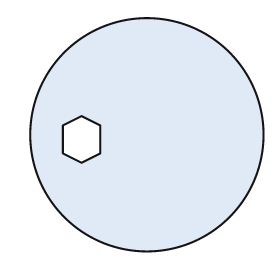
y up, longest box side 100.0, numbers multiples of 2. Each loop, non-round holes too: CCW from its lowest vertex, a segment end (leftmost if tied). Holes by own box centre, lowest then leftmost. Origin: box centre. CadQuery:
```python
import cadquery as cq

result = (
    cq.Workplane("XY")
    .moveTo(0.0, 0.0)
    .circle(50.0)
    .moveTo(-28.0, -12.0)
    .lineTo(-20.0, -8.0)
    .lineTo(-20.0, 4.0)
    .lineTo(-28.0, 8.0)
    .lineTo(-36.0, 4.0)
    .lineTo(-36.0, -8.0)
    .close()
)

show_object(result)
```